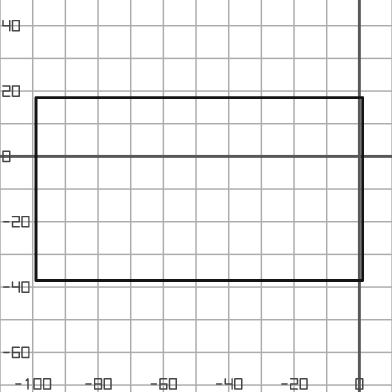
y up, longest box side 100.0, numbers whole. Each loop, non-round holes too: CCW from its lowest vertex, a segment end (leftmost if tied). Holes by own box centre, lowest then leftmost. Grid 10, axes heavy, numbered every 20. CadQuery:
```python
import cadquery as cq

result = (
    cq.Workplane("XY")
    .moveTo(-99.0, -38.0)
    .lineTo(1.0, -38.0)
    .lineTo(1.0, 18.0)
    .lineTo(-99.0, 18.0)
    .close()
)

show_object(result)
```